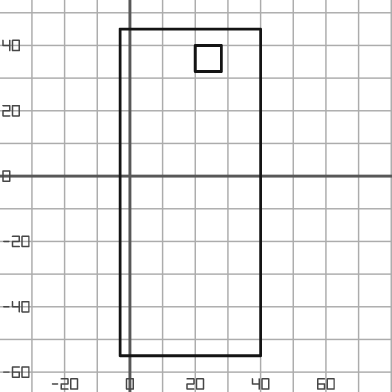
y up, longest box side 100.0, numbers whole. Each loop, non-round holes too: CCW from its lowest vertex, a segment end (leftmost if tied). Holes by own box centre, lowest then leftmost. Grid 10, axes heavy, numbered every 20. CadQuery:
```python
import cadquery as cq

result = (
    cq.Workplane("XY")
    .moveTo(-3.0, -55.0)
    .lineTo(40.0, -55.0)
    .lineTo(40.0, 45.0)
    .lineTo(-3.0, 45.0)
    .close()
    .moveTo(20.0, 32.0)
    .lineTo(28.0, 32.0)
    .lineTo(28.0, 40.0)
    .lineTo(20.0, 40.0)
    .close()
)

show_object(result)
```